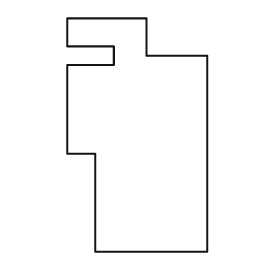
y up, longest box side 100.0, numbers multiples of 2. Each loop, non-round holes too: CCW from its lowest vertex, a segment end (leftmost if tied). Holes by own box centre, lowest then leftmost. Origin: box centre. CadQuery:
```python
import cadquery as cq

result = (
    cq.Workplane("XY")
    .moveTo(-18.0, -50.0)
    .lineTo(30.0, -50.0)
    .lineTo(30.0, 34.0)
    .lineTo(4.0, 34.0)
    .lineTo(4.0, 50.0)
    .lineTo(-30.0, 50.0)
    .lineTo(-30.0, 38.0)
    .lineTo(-10.0, 38.0)
    .lineTo(-10.0, 30.0)
    .lineTo(-30.0, 30.0)
    .lineTo(-30.0, -8.0)
    .lineTo(-18.0, -8.0)
    .close()
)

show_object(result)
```